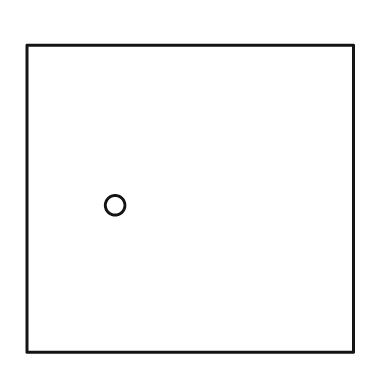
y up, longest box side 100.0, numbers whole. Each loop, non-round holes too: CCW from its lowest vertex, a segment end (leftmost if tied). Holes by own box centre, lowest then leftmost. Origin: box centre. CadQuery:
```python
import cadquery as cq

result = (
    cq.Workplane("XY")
    .moveTo(-50.0, -47.0)
    .lineTo(50.0, -47.0)
    .lineTo(50.0, 47.0)
    .lineTo(-50.0, 47.0)
    .close()
    .moveTo(-23.0, -2.0)
    .circle(3.0)
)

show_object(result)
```